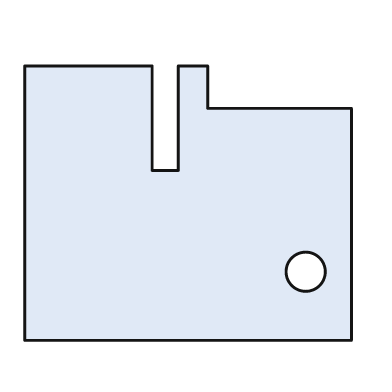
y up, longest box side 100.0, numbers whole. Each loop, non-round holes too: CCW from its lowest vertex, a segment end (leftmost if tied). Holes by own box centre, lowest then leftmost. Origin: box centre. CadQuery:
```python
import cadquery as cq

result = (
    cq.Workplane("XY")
    .moveTo(-50.0, -42.0)
    .lineTo(50.0, -42.0)
    .lineTo(50.0, 29.0)
    .lineTo(6.0, 29.0)
    .lineTo(6.0, 42.0)
    .lineTo(-3.0, 42.0)
    .lineTo(-3.0, 10.0)
    .lineTo(-11.0, 10.0)
    .lineTo(-11.0, 42.0)
    .lineTo(-50.0, 42.0)
    .close()
    .moveTo(36.0, -21.0)
    .circle(6.0)
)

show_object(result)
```